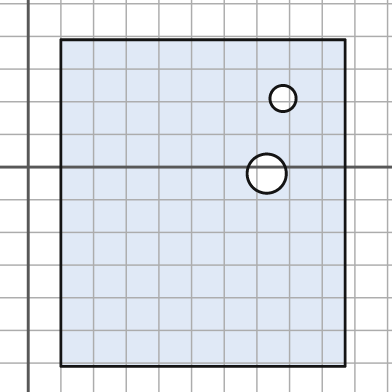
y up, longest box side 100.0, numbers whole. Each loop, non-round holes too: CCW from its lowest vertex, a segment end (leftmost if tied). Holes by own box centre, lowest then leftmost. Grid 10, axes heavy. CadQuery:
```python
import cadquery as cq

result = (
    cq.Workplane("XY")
    .moveTo(10.0, -61.0)
    .lineTo(97.0, -61.0)
    .lineTo(97.0, 39.0)
    .lineTo(10.0, 39.0)
    .close()
    .moveTo(73.0, -2.0)
    .circle(6.0)
    .moveTo(78.0, 21.0)
    .circle(4.0)
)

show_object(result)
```